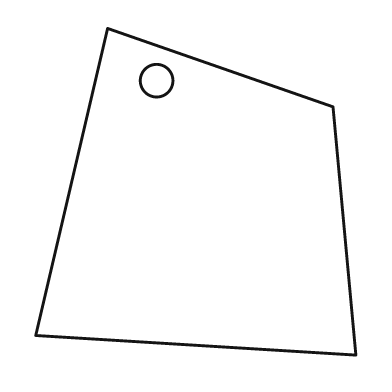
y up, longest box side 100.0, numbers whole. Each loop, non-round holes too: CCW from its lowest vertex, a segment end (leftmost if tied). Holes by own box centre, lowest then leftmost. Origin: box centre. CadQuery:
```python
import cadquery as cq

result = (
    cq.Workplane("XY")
    .moveTo(49.0, -50.0)
    .lineTo(42.0, 26.0)
    .lineTo(-27.0, 50.0)
    .lineTo(-49.0, -44.0)
    .close()
    .moveTo(-12.0, 34.0)
    .circle(5.0)
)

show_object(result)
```